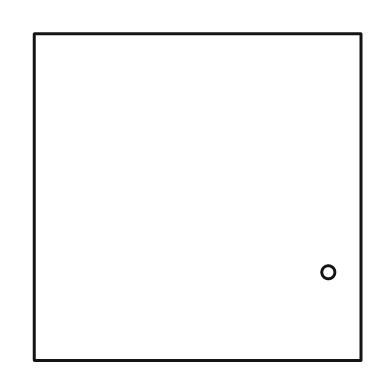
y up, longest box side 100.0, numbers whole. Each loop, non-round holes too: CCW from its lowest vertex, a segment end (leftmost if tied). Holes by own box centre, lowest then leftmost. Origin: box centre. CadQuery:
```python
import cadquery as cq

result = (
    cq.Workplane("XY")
    .moveTo(-50.0, -50.0)
    .lineTo(50.0, -50.0)
    .lineTo(50.0, 50.0)
    .lineTo(-50.0, 50.0)
    .close()
    .moveTo(40.0, -23.0)
    .circle(2.0)
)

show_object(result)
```